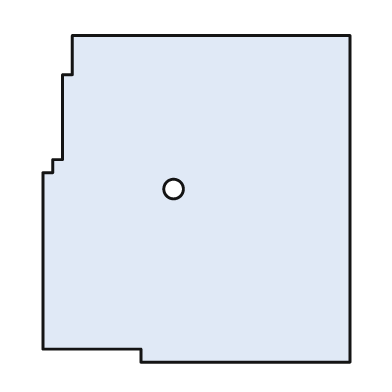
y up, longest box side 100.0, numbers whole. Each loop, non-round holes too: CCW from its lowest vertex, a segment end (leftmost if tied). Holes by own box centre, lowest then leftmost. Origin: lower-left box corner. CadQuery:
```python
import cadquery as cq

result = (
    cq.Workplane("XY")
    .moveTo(30.0, 0.0)
    .lineTo(94.0, 0.0)
    .lineTo(94.0, 100.0)
    .lineTo(9.0, 100.0)
    .lineTo(9.0, 88.0)
    .lineTo(6.0, 88.0)
    .lineTo(6.0, 62.0)
    .lineTo(3.0, 62.0)
    .lineTo(3.0, 58.0)
    .lineTo(0.0, 58.0)
    .lineTo(0.0, 4.0)
    .lineTo(30.0, 4.0)
    .close()
    .moveTo(40.0, 53.0)
    .circle(3.0)
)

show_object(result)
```